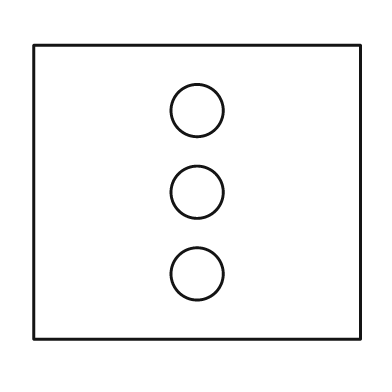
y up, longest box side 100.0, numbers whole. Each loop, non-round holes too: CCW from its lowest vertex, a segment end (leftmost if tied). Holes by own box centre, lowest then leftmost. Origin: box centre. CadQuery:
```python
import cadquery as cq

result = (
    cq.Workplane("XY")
    .moveTo(-50.0, -45.0)
    .lineTo(50.0, -45.0)
    .lineTo(50.0, 45.0)
    .lineTo(-50.0, 45.0)
    .close()
    .moveTo(0.0, -25.0)
    .circle(8.0)
    .moveTo(0.0, 0.0)
    .circle(8.0)
    .moveTo(0.0, 25.0)
    .circle(8.0)
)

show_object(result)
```